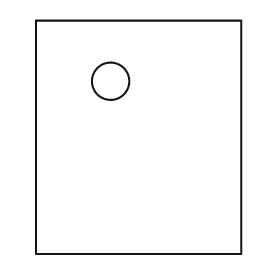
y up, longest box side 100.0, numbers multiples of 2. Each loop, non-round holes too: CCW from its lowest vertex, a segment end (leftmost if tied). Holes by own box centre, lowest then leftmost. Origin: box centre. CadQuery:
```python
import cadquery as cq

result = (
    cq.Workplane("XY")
    .moveTo(-44.0, -50.0)
    .lineTo(44.0, -50.0)
    .lineTo(44.0, 50.0)
    .lineTo(-44.0, 50.0)
    .close()
    .moveTo(-12.0, 24.0)
    .circle(8.0)
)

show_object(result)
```